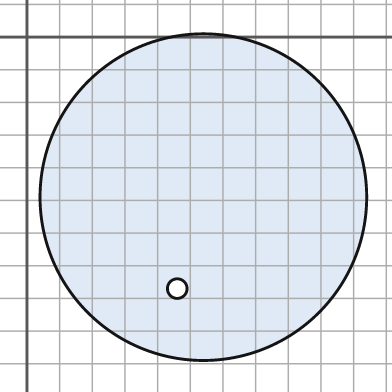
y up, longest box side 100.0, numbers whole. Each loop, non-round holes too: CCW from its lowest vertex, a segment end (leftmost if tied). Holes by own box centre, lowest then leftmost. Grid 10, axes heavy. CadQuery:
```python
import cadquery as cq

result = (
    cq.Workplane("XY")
    .moveTo(54.0, -49.0)
    .circle(50.0)
    .moveTo(46.0, -77.0)
    .circle(3.0)
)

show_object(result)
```